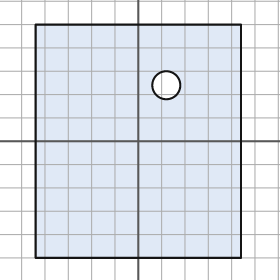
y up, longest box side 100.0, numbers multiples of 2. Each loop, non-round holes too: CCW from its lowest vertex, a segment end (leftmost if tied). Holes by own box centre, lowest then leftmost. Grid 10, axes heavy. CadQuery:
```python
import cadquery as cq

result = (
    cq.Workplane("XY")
    .moveTo(-44.0, -50.0)
    .lineTo(44.0, -50.0)
    .lineTo(44.0, 50.0)
    .lineTo(-44.0, 50.0)
    .close()
    .moveTo(12.0, 24.0)
    .circle(6.0)
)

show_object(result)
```